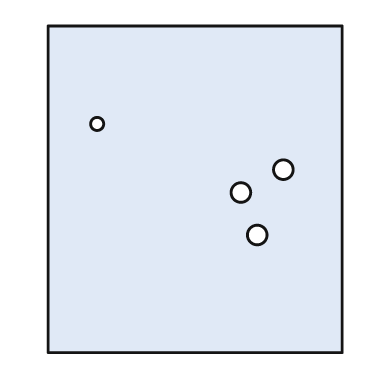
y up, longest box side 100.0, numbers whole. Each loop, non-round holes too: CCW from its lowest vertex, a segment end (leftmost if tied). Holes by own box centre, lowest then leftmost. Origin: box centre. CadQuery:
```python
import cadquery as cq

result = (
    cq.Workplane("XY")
    .moveTo(-45.0, -50.0)
    .lineTo(45.0, -50.0)
    .lineTo(45.0, 50.0)
    .lineTo(-45.0, 50.0)
    .close()
    .moveTo(19.0, -14.0)
    .circle(3.0)
    .moveTo(14.0, -1.0)
    .circle(3.0)
    .moveTo(27.0, 6.0)
    .circle(3.0)
    .moveTo(-30.0, 20.0)
    .circle(2.0)
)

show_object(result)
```